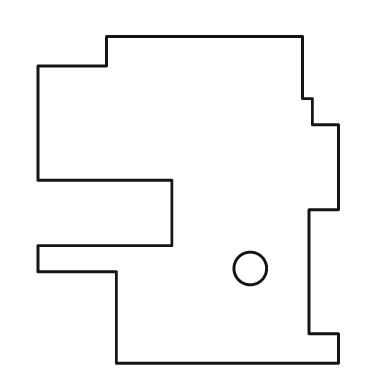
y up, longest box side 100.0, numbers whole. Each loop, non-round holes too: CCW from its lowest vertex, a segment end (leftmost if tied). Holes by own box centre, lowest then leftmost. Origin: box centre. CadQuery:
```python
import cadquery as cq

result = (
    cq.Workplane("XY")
    .moveTo(-22.0, -50.0)
    .lineTo(46.0, -50.0)
    .lineTo(46.0, -41.0)
    .lineTo(37.0, -41.0)
    .lineTo(37.0, -3.0)
    .lineTo(46.0, -3.0)
    .lineTo(46.0, 23.0)
    .lineTo(38.0, 23.0)
    .lineTo(38.0, 31.0)
    .lineTo(35.0, 31.0)
    .lineTo(35.0, 50.0)
    .lineTo(-25.0, 50.0)
    .lineTo(-25.0, 41.0)
    .lineTo(-46.0, 41.0)
    .lineTo(-46.0, 6.0)
    .lineTo(-5.0, 6.0)
    .lineTo(-5.0, -14.0)
    .lineTo(-46.0, -14.0)
    .lineTo(-46.0, -22.0)
    .lineTo(-22.0, -22.0)
    .close()
    .moveTo(19.0, -21.0)
    .circle(5.0)
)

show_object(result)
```